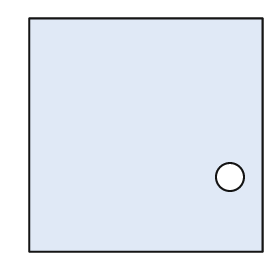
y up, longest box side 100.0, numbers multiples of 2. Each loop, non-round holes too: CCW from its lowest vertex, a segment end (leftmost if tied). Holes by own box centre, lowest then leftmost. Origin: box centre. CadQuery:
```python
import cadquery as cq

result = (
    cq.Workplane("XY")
    .moveTo(-50.0, -50.0)
    .lineTo(50.0, -50.0)
    .lineTo(50.0, 50.0)
    .lineTo(-50.0, 50.0)
    .close()
    .moveTo(36.0, -18.0)
    .circle(6.0)
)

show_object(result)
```